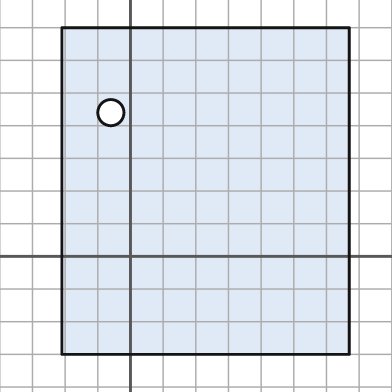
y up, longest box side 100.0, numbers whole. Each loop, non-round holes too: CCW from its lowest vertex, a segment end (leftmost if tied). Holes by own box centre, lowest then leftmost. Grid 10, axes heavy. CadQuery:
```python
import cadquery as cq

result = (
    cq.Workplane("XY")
    .moveTo(-21.0, -30.0)
    .lineTo(67.0, -30.0)
    .lineTo(67.0, 70.0)
    .lineTo(-21.0, 70.0)
    .close()
    .moveTo(-6.0, 44.0)
    .circle(4.0)
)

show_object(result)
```